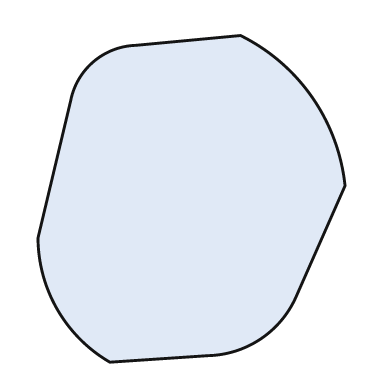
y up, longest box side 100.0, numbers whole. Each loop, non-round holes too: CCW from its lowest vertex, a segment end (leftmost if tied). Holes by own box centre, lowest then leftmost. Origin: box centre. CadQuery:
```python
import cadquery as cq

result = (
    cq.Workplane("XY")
    .moveTo(-25.0, -50.0)
    .lineTo(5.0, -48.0)
    .threePointArc((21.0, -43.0), (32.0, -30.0))
    .lineTo(47.0, 4.0)
    .threePointArc((37.0, 31.0), (15.0, 50.0))
    .lineTo(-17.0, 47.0)
    .threePointArc((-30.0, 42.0), (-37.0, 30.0))
    .lineTo(-47.0, -12.0)
    .threePointArc((-41.0, -34.0), (-25.0, -50.0))
    .close()
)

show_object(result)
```